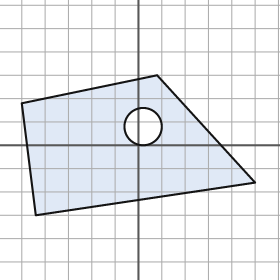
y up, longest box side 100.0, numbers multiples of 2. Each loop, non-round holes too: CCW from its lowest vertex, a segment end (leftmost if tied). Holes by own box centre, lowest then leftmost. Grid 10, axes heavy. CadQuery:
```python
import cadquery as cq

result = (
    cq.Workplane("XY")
    .moveTo(-44.0, -30.0)
    .lineTo(50.0, -16.0)
    .lineTo(8.0, 30.0)
    .lineTo(-50.0, 18.0)
    .close()
    .moveTo(2.0, 8.0)
    .circle(8.0)
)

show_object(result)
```